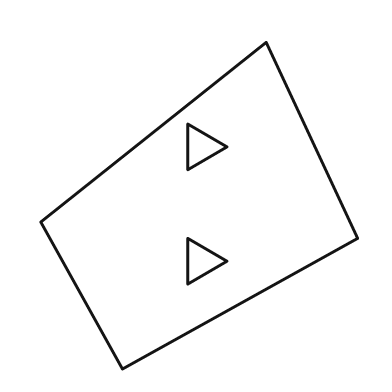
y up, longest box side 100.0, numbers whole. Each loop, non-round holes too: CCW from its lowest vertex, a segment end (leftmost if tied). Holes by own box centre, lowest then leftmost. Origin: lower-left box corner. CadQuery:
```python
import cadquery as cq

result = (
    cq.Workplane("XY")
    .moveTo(25.0, 0.0)
    .lineTo(97.0, 40.0)
    .lineTo(69.0, 100.0)
    .lineTo(0.0, 45.0)
    .close()
    .moveTo(45.0, 26.0)
    .lineTo(57.0, 33.0)
    .lineTo(45.0, 40.0)
    .close()
    .moveTo(45.0, 61.0)
    .lineTo(57.0, 68.0)
    .lineTo(45.0, 75.0)
    .close()
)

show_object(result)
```